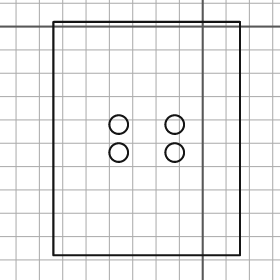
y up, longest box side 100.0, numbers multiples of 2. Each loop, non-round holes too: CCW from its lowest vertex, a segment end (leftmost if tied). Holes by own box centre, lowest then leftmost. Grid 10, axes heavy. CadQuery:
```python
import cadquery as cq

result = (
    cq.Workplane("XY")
    .moveTo(-64.0, -98.0)
    .lineTo(16.0, -98.0)
    .lineTo(16.0, 2.0)
    .lineTo(-64.0, 2.0)
    .close()
    .moveTo(-36.0, -54.0)
    .circle(4.0)
    .moveTo(-12.0, -54.0)
    .circle(4.0)
    .moveTo(-36.0, -42.0)
    .circle(4.0)
    .moveTo(-12.0, -42.0)
    .circle(4.0)
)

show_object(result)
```